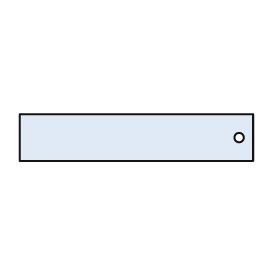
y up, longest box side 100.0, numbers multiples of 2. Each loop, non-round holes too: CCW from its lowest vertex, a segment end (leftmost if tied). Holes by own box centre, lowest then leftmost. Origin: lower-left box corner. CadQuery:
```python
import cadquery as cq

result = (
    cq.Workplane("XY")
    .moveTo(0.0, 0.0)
    .lineTo(100.0, 0.0)
    .lineTo(100.0, 20.0)
    .lineTo(0.0, 20.0)
    .close()
    .moveTo(94.0, 10.0)
    .circle(2.0)
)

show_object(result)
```